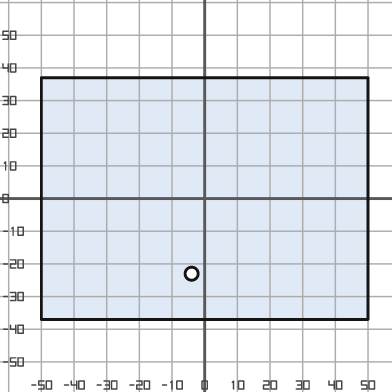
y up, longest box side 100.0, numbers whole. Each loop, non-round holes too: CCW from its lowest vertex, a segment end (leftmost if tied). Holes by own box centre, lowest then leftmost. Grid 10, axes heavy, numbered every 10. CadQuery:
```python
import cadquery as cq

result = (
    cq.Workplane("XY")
    .moveTo(-50.0, -37.0)
    .lineTo(50.0, -37.0)
    .lineTo(50.0, 37.0)
    .lineTo(-50.0, 37.0)
    .close()
    .moveTo(-4.0, -23.0)
    .circle(2.0)
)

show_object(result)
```